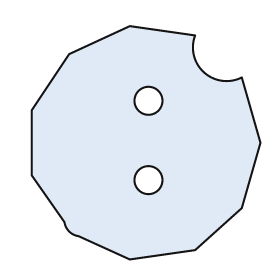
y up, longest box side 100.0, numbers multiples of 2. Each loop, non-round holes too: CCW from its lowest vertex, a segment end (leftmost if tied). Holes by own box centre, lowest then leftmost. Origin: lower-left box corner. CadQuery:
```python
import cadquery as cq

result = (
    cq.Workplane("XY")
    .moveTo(42.0, 0.0)
    .lineTo(70.0, 4.0)
    .lineTo(90.0, 22.0)
    .lineTo(98.0, 50.0)
    .lineTo(90.0, 78.0)
    .threePointArc((74.0, 80.0), (70.0, 96.0))
    .lineTo(42.0, 100.0)
    .lineTo(16.0, 88.0)
    .lineTo(0.0, 64.0)
    .lineTo(0.0, 36.0)
    .lineTo(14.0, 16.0)
    .threePointArc((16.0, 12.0), (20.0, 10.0))
    .close()
    .moveTo(50.0, 34.0)
    .circle(6.0)
    .moveTo(50.0, 68.0)
    .circle(6.0)
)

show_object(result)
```